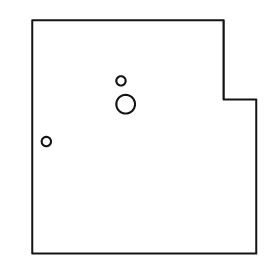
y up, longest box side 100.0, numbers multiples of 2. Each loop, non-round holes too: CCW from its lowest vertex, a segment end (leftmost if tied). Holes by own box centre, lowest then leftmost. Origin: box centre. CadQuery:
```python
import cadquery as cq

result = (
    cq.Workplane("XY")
    .moveTo(-48.0, -50.0)
    .lineTo(48.0, -50.0)
    .lineTo(48.0, 16.0)
    .lineTo(34.0, 16.0)
    .lineTo(34.0, 50.0)
    .lineTo(-48.0, 50.0)
    .close()
    .moveTo(-42.0, -2.0)
    .circle(2.0)
    .moveTo(-8.0, 14.0)
    .circle(4.0)
    .moveTo(-10.0, 24.0)
    .circle(2.0)
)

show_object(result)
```